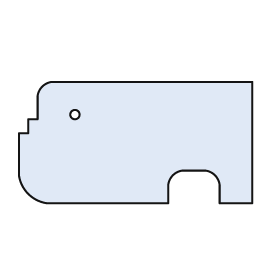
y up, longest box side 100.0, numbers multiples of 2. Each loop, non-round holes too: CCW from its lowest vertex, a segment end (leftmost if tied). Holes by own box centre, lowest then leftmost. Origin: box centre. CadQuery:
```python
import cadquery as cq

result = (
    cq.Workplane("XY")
    .moveTo(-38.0, -26.0)
    .lineTo(14.0, -26.0)
    .lineTo(14.0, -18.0)
    .threePointArc((16.0, -14.0), (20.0, -12.0))
    .lineTo(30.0, -12.0)
    .threePointArc((34.0, -14.0), (36.0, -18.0))
    .lineTo(36.0, -26.0)
    .lineTo(50.0, -26.0)
    .lineTo(50.0, 26.0)
    .lineTo(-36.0, 26.0)
    .threePointArc((-40.0, 24.0), (-42.0, 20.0))
    .lineTo(-42.0, 10.0)
    .lineTo(-46.0, 10.0)
    .lineTo(-46.0, 4.0)
    .lineTo(-50.0, 4.0)
    .lineTo(-50.0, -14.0)
    .threePointArc((-46.0, -22.0), (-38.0, -26.0))
    .close()
    .moveTo(-26.0, 12.0)
    .circle(2.0)
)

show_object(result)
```